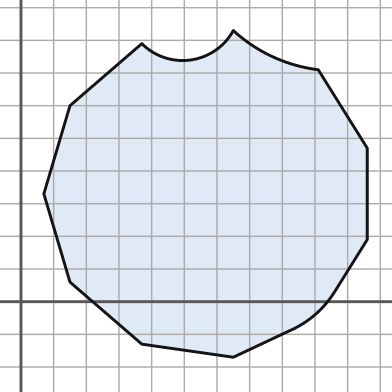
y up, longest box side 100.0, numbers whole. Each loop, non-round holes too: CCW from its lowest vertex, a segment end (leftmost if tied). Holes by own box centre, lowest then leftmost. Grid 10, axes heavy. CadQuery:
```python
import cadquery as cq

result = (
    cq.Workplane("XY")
    .moveTo(65.0, -17.0)
    .lineTo(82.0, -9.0)
    .threePointArc((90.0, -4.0), (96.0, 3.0))
    .lineTo(106.0, 19.0)
    .lineTo(106.0, 47.0)
    .lineTo(91.0, 71.0)
    .threePointArc((77.0, 75.0), (65.0, 83.0))
    .threePointArc((52.0, 74.0), (37.0, 79.0))
    .lineTo(15.0, 60.0)
    .lineTo(7.0, 33.0)
    .lineTo(15.0, 6.0)
    .lineTo(37.0, -13.0)
    .close()
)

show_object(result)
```